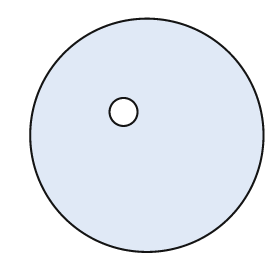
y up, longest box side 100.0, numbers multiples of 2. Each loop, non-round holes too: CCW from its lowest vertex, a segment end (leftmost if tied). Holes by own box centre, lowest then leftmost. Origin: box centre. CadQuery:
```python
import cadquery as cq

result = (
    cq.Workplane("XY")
    .moveTo(0.0, 0.0)
    .circle(50.0)
    .moveTo(-10.0, 10.0)
    .circle(6.0)
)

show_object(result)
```